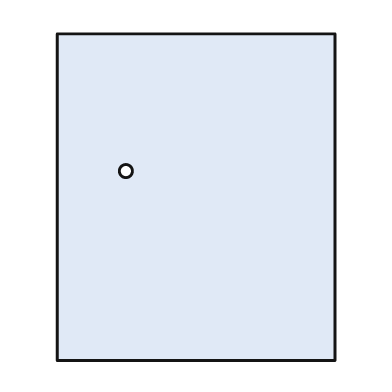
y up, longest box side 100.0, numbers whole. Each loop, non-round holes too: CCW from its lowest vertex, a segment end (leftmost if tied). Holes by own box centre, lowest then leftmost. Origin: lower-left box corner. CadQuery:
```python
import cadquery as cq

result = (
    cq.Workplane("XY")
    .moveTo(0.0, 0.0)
    .lineTo(85.0, 0.0)
    .lineTo(85.0, 100.0)
    .lineTo(0.0, 100.0)
    .close()
    .moveTo(21.0, 58.0)
    .circle(2.0)
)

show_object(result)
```